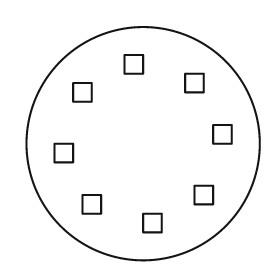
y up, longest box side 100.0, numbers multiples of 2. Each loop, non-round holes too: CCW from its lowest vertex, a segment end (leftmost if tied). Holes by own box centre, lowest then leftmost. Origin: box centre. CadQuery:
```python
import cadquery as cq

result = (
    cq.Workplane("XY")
    .moveTo(0.0, 0.0)
    .circle(50.0)
    .moveTo(0.0, -38.0)
    .lineTo(8.0, -38.0)
    .lineTo(8.0, -30.0)
    .lineTo(0.0, -30.0)
    .close()
    .moveTo(-26.0, -30.0)
    .lineTo(-18.0, -30.0)
    .lineTo(-18.0, -22.0)
    .lineTo(-26.0, -22.0)
    .close()
    .moveTo(22.0, -26.0)
    .lineTo(30.0, -26.0)
    .lineTo(30.0, -18.0)
    .lineTo(22.0, -18.0)
    .close()
    .moveTo(-38.0, -8.0)
    .lineTo(-30.0, -8.0)
    .lineTo(-30.0, 0.0)
    .lineTo(-38.0, 0.0)
    .close()
    .moveTo(30.0, 0.0)
    .lineTo(38.0, 0.0)
    .lineTo(38.0, 8.0)
    .lineTo(30.0, 8.0)
    .close()
    .moveTo(-30.0, 18.0)
    .lineTo(-22.0, 18.0)
    .lineTo(-22.0, 26.0)
    .lineTo(-30.0, 26.0)
    .close()
    .moveTo(18.0, 22.0)
    .lineTo(26.0, 22.0)
    .lineTo(26.0, 30.0)
    .lineTo(18.0, 30.0)
    .close()
    .moveTo(-8.0, 30.0)
    .lineTo(0.0, 30.0)
    .lineTo(0.0, 38.0)
    .lineTo(-8.0, 38.0)
    .close()
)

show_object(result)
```